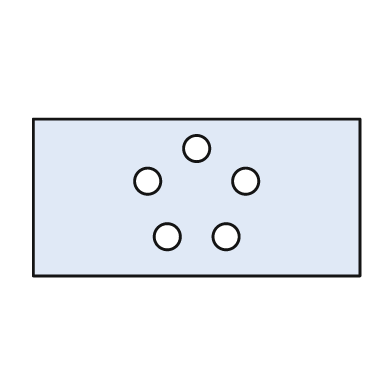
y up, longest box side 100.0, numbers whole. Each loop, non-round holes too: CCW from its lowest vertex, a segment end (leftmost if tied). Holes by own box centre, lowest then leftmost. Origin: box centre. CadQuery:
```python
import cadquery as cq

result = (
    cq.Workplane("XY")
    .moveTo(-50.0, -24.0)
    .lineTo(50.0, -24.0)
    .lineTo(50.0, 24.0)
    .lineTo(-50.0, 24.0)
    .close()
    .moveTo(-9.0, -12.0)
    .circle(4.0)
    .moveTo(9.0, -12.0)
    .circle(4.0)
    .moveTo(-15.0, 5.0)
    .circle(4.0)
    .moveTo(15.0, 5.0)
    .circle(4.0)
    .moveTo(0.0, 15.0)
    .circle(4.0)
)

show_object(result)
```